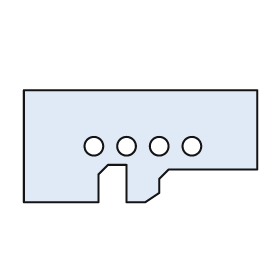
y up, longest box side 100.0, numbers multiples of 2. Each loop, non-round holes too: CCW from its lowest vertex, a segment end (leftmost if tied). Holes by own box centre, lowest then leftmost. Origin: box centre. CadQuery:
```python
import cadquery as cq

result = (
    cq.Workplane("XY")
    .moveTo(-50.0, -24.0)
    .lineTo(-18.0, -24.0)
    .lineTo(-18.0, -12.0)
    .lineTo(-14.0, -8.0)
    .lineTo(-6.0, -8.0)
    .lineTo(-6.0, -24.0)
    .lineTo(2.0, -24.0)
    .lineTo(8.0, -20.0)
    .lineTo(8.0, -14.0)
    .lineTo(12.0, -10.0)
    .lineTo(50.0, -10.0)
    .lineTo(50.0, 24.0)
    .lineTo(-50.0, 24.0)
    .close()
    .moveTo(-20.0, 0.0)
    .circle(4.0)
    .moveTo(-6.0, 0.0)
    .circle(4.0)
    .moveTo(8.0, 0.0)
    .circle(4.0)
    .moveTo(22.0, 0.0)
    .circle(4.0)
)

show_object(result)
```